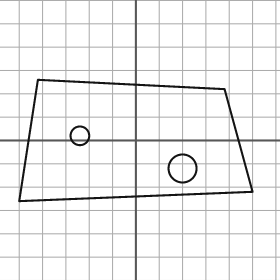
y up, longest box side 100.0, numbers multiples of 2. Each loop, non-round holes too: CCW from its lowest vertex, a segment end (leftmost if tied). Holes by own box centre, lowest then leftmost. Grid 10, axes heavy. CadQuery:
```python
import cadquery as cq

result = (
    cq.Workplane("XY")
    .moveTo(-50.0, -26.0)
    .lineTo(50.0, -22.0)
    .lineTo(38.0, 22.0)
    .lineTo(-42.0, 26.0)
    .close()
    .moveTo(20.0, -12.0)
    .circle(6.0)
    .moveTo(-24.0, 2.0)
    .circle(4.0)
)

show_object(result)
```